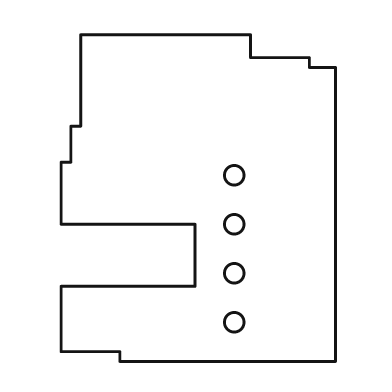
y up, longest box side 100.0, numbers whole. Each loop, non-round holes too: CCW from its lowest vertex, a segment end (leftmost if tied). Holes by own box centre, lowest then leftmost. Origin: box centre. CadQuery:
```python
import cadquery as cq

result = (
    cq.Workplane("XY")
    .moveTo(-24.0, -50.0)
    .lineTo(42.0, -50.0)
    .lineTo(42.0, 40.0)
    .lineTo(34.0, 40.0)
    .lineTo(34.0, 43.0)
    .lineTo(16.0, 43.0)
    .lineTo(16.0, 50.0)
    .lineTo(-36.0, 50.0)
    .lineTo(-36.0, 22.0)
    .lineTo(-39.0, 22.0)
    .lineTo(-39.0, 11.0)
    .lineTo(-42.0, 11.0)
    .lineTo(-42.0, -8.0)
    .lineTo(-1.0, -8.0)
    .lineTo(-1.0, -27.0)
    .lineTo(-42.0, -27.0)
    .lineTo(-42.0, -47.0)
    .lineTo(-24.0, -47.0)
    .close()
    .moveTo(11.0, -38.0)
    .circle(3.0)
    .moveTo(11.0, -23.0)
    .circle(3.0)
    .moveTo(11.0, -8.0)
    .circle(3.0)
    .moveTo(11.0, 7.0)
    .circle(3.0)
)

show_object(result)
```